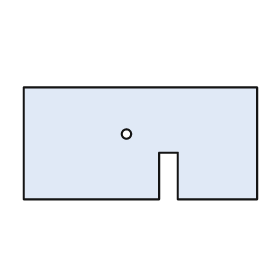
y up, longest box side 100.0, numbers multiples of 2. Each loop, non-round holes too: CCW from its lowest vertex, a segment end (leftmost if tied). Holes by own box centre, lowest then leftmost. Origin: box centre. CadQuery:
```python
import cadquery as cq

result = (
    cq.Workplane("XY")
    .moveTo(-50.0, -24.0)
    .lineTo(8.0, -24.0)
    .lineTo(8.0, -4.0)
    .lineTo(16.0, -4.0)
    .lineTo(16.0, -24.0)
    .lineTo(50.0, -24.0)
    .lineTo(50.0, 24.0)
    .lineTo(-50.0, 24.0)
    .close()
    .moveTo(-6.0, 4.0)
    .circle(2.0)
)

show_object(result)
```